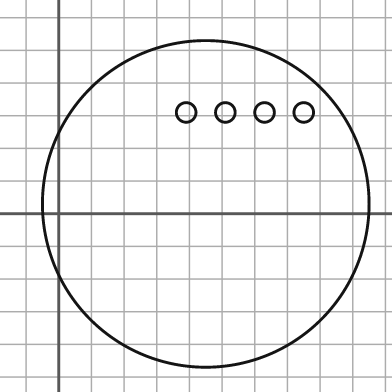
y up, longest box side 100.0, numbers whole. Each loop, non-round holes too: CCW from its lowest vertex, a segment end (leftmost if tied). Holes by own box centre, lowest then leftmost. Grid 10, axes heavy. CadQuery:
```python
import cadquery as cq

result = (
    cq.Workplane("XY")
    .moveTo(45.0, 3.0)
    .circle(50.0)
    .moveTo(39.0, 31.0)
    .circle(3.0)
    .moveTo(51.0, 31.0)
    .circle(3.0)
    .moveTo(63.0, 31.0)
    .circle(3.0)
    .moveTo(75.0, 31.0)
    .circle(3.0)
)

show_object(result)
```